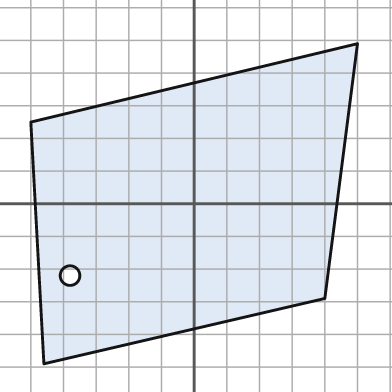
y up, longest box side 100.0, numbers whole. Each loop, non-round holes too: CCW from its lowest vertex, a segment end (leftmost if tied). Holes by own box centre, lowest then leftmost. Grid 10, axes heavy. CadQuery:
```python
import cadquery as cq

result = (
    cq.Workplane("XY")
    .moveTo(-46.0, -49.0)
    .lineTo(40.0, -29.0)
    .lineTo(50.0, 49.0)
    .lineTo(-50.0, 25.0)
    .close()
    .moveTo(-38.0, -22.0)
    .circle(3.0)
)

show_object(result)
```